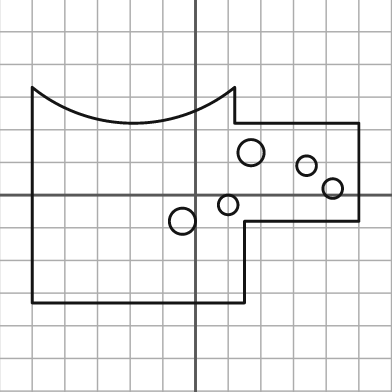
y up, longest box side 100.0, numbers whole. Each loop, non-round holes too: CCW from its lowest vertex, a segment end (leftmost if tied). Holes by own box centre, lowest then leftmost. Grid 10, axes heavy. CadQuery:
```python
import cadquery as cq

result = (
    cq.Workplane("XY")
    .moveTo(-50.0, -33.0)
    .lineTo(15.0, -33.0)
    .lineTo(15.0, -8.0)
    .lineTo(50.0, -8.0)
    .lineTo(50.0, 22.0)
    .lineTo(12.0, 22.0)
    .lineTo(12.0, 33.0)
    .threePointArc((-19.0, 22.0), (-50.0, 33.0))
    .close()
    .moveTo(-4.0, -8.0)
    .circle(4.0)
    .moveTo(10.0, -3.0)
    .circle(3.0)
    .moveTo(42.0, 2.0)
    .circle(3.0)
    .moveTo(34.0, 9.0)
    .circle(3.0)
    .moveTo(17.0, 13.0)
    .circle(4.0)
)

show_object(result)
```